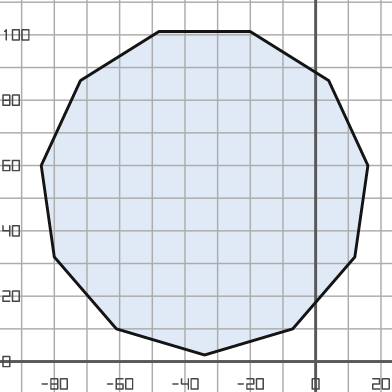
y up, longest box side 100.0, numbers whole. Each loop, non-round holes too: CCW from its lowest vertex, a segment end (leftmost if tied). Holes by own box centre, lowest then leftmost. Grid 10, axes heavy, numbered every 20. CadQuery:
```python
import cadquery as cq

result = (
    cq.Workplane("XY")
    .moveTo(-34.0, 2.0)
    .lineTo(-7.0, 10.0)
    .lineTo(12.0, 32.0)
    .lineTo(16.0, 60.0)
    .lineTo(4.0, 86.0)
    .lineTo(-20.0, 101.0)
    .lineTo(-48.0, 101.0)
    .lineTo(-72.0, 86.0)
    .lineTo(-84.0, 60.0)
    .lineTo(-80.0, 32.0)
    .lineTo(-61.0, 10.0)
    .close()
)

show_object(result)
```